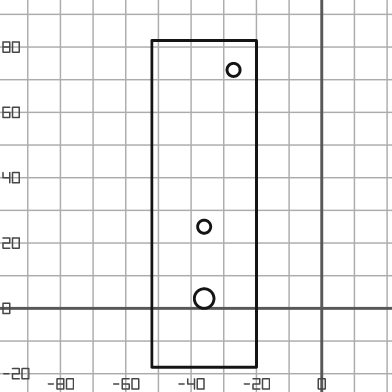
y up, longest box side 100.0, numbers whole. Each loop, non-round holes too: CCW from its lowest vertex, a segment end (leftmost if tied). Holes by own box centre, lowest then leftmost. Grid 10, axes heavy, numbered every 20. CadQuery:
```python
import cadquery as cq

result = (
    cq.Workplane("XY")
    .moveTo(-52.0, -18.0)
    .lineTo(-20.0, -18.0)
    .lineTo(-20.0, 82.0)
    .lineTo(-52.0, 82.0)
    .close()
    .moveTo(-36.0, 3.0)
    .circle(3.0)
    .moveTo(-36.0, 25.0)
    .circle(2.0)
    .moveTo(-27.0, 73.0)
    .circle(2.0)
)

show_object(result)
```